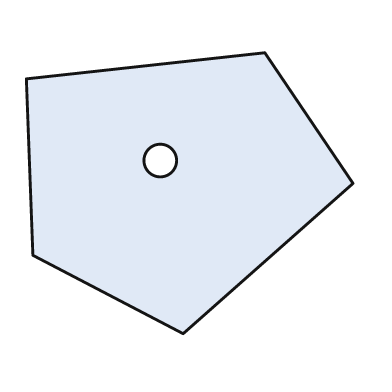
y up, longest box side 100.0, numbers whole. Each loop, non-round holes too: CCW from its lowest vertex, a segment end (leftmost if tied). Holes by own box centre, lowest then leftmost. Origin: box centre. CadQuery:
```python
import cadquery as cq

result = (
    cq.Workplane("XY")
    .moveTo(-2.0, -43.0)
    .lineTo(50.0, 3.0)
    .lineTo(23.0, 43.0)
    .lineTo(-50.0, 35.0)
    .lineTo(-48.0, -19.0)
    .close()
    .moveTo(-9.0, 10.0)
    .circle(5.0)
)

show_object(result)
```